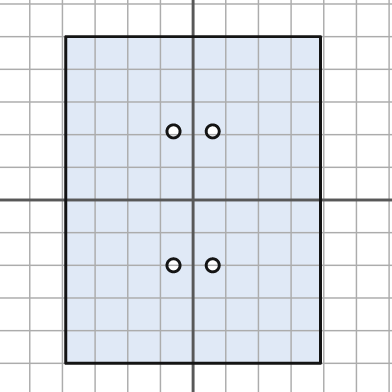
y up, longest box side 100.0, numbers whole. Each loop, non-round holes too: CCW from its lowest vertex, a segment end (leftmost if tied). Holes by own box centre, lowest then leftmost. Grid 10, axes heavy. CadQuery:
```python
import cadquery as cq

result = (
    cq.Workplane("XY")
    .moveTo(-39.0, -50.0)
    .lineTo(39.0, -50.0)
    .lineTo(39.0, 50.0)
    .lineTo(-39.0, 50.0)
    .close()
    .moveTo(-6.0, -20.0)
    .circle(2.0)
    .moveTo(6.0, -20.0)
    .circle(2.0)
    .moveTo(-6.0, 21.0)
    .circle(2.0)
    .moveTo(6.0, 21.0)
    .circle(2.0)
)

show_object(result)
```